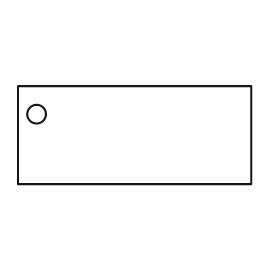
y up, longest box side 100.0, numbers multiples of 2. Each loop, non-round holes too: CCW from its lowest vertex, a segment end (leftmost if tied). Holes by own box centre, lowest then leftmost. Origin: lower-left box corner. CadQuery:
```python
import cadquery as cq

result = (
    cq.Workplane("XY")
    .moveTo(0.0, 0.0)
    .lineTo(100.0, 0.0)
    .lineTo(100.0, 42.0)
    .lineTo(0.0, 42.0)
    .close()
    .moveTo(8.0, 30.0)
    .circle(4.0)
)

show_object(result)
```